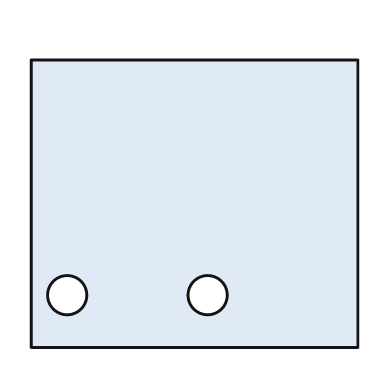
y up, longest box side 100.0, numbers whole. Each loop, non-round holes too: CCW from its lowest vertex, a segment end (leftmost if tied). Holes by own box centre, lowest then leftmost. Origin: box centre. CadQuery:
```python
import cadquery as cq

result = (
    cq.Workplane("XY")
    .moveTo(-50.0, -44.0)
    .lineTo(50.0, -44.0)
    .lineTo(50.0, 44.0)
    .lineTo(-50.0, 44.0)
    .close()
    .moveTo(-39.0, -28.0)
    .circle(6.0)
    .moveTo(4.0, -28.0)
    .circle(6.0)
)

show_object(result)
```